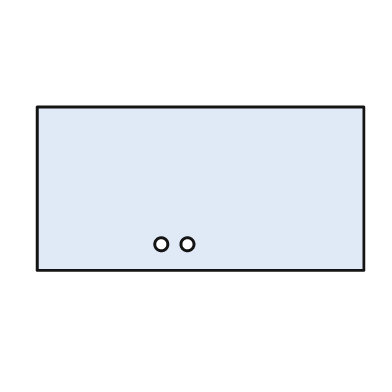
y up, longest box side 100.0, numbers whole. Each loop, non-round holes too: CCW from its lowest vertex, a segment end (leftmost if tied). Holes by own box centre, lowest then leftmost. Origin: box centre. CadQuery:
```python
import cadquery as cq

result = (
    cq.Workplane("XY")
    .moveTo(-50.0, -25.0)
    .lineTo(50.0, -25.0)
    .lineTo(50.0, 25.0)
    .lineTo(-50.0, 25.0)
    .close()
    .moveTo(-12.0, -17.0)
    .circle(2.0)
    .moveTo(-4.0, -17.0)
    .circle(2.0)
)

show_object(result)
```